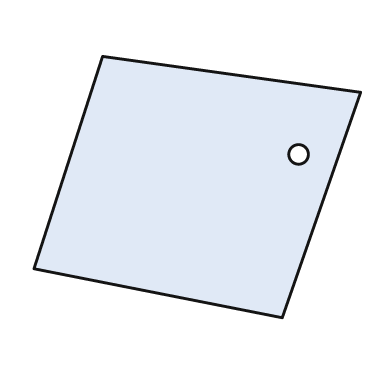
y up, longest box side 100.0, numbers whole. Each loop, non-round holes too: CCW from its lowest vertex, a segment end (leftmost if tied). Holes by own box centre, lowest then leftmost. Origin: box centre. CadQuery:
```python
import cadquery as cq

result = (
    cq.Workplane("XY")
    .moveTo(26.0, -40.0)
    .lineTo(50.0, 29.0)
    .lineTo(-29.0, 40.0)
    .lineTo(-50.0, -25.0)
    .close()
    .moveTo(31.0, 10.0)
    .circle(3.0)
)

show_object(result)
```